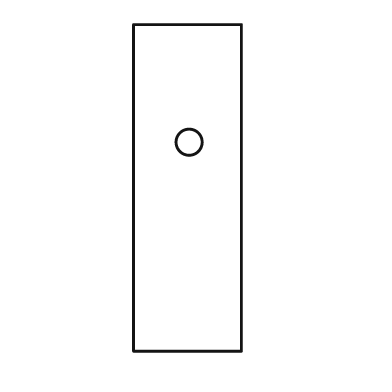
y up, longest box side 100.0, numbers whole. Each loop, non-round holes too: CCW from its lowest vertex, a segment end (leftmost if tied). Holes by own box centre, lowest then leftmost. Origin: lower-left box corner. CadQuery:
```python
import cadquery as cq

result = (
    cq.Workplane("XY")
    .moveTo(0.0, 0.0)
    .lineTo(33.0, 0.0)
    .lineTo(33.0, 100.0)
    .lineTo(0.0, 100.0)
    .close()
    .moveTo(17.0, 64.0)
    .circle(4.0)
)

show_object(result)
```